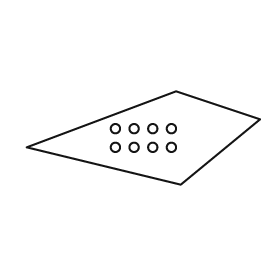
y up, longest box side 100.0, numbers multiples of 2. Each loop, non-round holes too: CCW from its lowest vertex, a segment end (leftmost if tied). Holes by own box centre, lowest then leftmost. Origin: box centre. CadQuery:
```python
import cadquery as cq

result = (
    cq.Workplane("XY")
    .moveTo(16.0, -20.0)
    .lineTo(50.0, 8.0)
    .lineTo(14.0, 20.0)
    .lineTo(-50.0, -4.0)
    .close()
    .moveTo(-12.0, -4.0)
    .circle(2.0)
    .moveTo(-4.0, -4.0)
    .circle(2.0)
    .moveTo(4.0, -4.0)
    .circle(2.0)
    .moveTo(12.0, -4.0)
    .circle(2.0)
    .moveTo(-12.0, 4.0)
    .circle(2.0)
    .moveTo(-4.0, 4.0)
    .circle(2.0)
    .moveTo(4.0, 4.0)
    .circle(2.0)
    .moveTo(12.0, 4.0)
    .circle(2.0)
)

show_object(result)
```